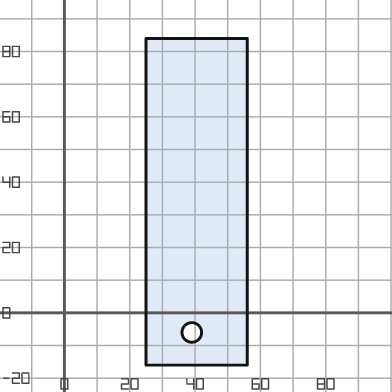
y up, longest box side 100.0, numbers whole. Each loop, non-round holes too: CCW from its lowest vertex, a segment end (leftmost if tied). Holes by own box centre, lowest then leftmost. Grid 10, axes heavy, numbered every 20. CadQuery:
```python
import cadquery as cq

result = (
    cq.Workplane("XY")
    .moveTo(25.0, -16.0)
    .lineTo(56.0, -16.0)
    .lineTo(56.0, 84.0)
    .lineTo(25.0, 84.0)
    .close()
    .moveTo(39.0, -6.0)
    .circle(3.0)
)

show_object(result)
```